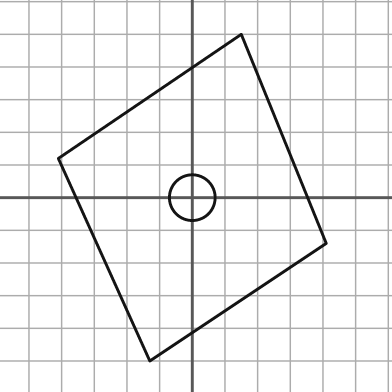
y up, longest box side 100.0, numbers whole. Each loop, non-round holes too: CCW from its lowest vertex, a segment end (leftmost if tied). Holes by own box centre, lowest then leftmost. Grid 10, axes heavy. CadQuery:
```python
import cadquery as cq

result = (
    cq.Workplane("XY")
    .moveTo(-13.0, -50.0)
    .lineTo(41.0, -14.0)
    .lineTo(15.0, 50.0)
    .lineTo(-41.0, 12.0)
    .close()
    .moveTo(0.0, 0.0)
    .circle(7.0)
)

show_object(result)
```